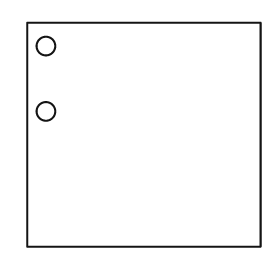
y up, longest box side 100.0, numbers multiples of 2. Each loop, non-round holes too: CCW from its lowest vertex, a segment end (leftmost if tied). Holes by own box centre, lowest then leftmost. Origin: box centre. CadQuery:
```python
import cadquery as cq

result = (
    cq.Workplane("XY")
    .moveTo(-50.0, -48.0)
    .lineTo(50.0, -48.0)
    .lineTo(50.0, 48.0)
    .lineTo(-50.0, 48.0)
    .close()
    .moveTo(-42.0, 10.0)
    .circle(4.0)
    .moveTo(-42.0, 38.0)
    .circle(4.0)
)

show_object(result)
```